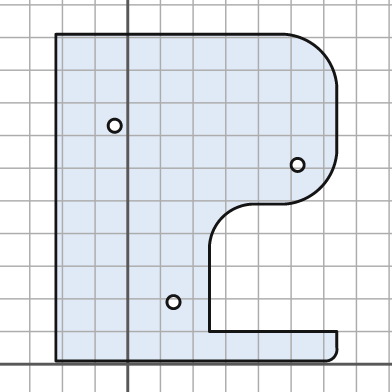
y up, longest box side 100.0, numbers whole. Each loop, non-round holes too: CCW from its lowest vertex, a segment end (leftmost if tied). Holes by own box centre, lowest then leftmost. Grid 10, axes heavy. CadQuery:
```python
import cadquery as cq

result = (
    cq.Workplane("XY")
    .moveTo(-22.0, 1.0)
    .lineTo(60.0, 1.0)
    .threePointArc((63.0, 2.0), (64.0, 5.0))
    .lineTo(64.0, 10.0)
    .lineTo(25.0, 10.0)
    .lineTo(25.0, 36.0)
    .threePointArc((29.0, 45.0), (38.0, 49.0))
    .lineTo(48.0, 49.0)
    .threePointArc((59.0, 54.0), (64.0, 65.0))
    .lineTo(64.0, 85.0)
    .threePointArc((59.0, 96.0), (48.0, 101.0))
    .lineTo(-22.0, 101.0)
    .close()
    .moveTo(14.0, 19.0)
    .circle(2.0)
    .moveTo(52.0, 61.0)
    .circle(2.0)
    .moveTo(-4.0, 73.0)
    .circle(2.0)
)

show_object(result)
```